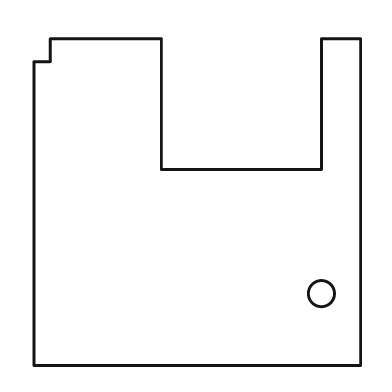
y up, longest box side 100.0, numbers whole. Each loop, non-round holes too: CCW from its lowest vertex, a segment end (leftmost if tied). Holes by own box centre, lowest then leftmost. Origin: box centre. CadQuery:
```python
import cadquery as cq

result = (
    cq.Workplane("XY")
    .moveTo(-50.0, -50.0)
    .lineTo(50.0, -50.0)
    .lineTo(50.0, 50.0)
    .lineTo(38.0, 50.0)
    .lineTo(38.0, 10.0)
    .lineTo(-11.0, 10.0)
    .lineTo(-11.0, 50.0)
    .lineTo(-45.0, 50.0)
    .lineTo(-45.0, 43.0)
    .lineTo(-50.0, 43.0)
    .close()
    .moveTo(38.0, -28.0)
    .circle(4.0)
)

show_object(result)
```